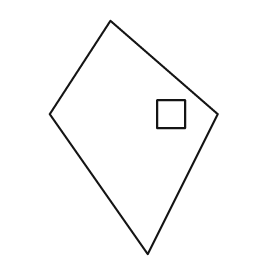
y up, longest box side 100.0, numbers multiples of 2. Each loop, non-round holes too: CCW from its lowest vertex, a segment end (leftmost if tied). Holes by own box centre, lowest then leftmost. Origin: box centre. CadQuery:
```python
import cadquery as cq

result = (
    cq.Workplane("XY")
    .moveTo(6.0, -50.0)
    .lineTo(36.0, 10.0)
    .lineTo(-10.0, 50.0)
    .lineTo(-36.0, 10.0)
    .close()
    .moveTo(10.0, 4.0)
    .lineTo(22.0, 4.0)
    .lineTo(22.0, 16.0)
    .lineTo(10.0, 16.0)
    .close()
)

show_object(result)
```